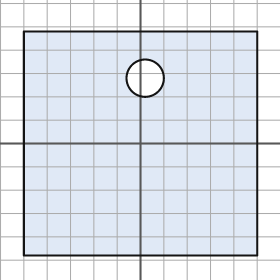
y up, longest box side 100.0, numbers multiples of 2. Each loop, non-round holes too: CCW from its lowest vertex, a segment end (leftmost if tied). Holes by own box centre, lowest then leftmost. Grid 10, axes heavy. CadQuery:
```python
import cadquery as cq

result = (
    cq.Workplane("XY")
    .moveTo(-50.0, -48.0)
    .lineTo(50.0, -48.0)
    .lineTo(50.0, 48.0)
    .lineTo(-50.0, 48.0)
    .close()
    .moveTo(2.0, 28.0)
    .circle(8.0)
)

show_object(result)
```